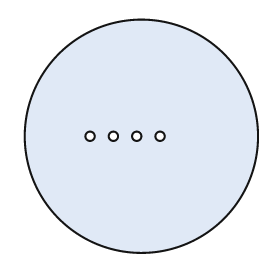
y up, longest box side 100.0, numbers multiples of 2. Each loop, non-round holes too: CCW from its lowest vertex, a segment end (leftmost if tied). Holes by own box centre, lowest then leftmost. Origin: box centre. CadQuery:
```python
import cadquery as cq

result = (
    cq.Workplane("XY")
    .moveTo(0.0, 0.0)
    .circle(50.0)
    .moveTo(-22.0, 0.0)
    .circle(2.0)
    .moveTo(-12.0, 0.0)
    .circle(2.0)
    .moveTo(-2.0, 0.0)
    .circle(2.0)
    .moveTo(8.0, 0.0)
    .circle(2.0)
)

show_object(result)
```